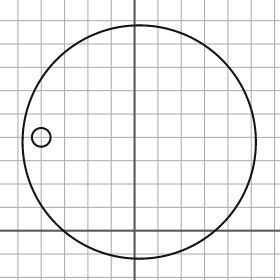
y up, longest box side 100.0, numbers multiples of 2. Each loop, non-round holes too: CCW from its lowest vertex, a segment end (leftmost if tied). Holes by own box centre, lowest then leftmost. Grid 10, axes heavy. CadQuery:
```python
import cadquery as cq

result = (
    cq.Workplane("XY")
    .moveTo(2.0, 38.0)
    .circle(50.0)
    .moveTo(-40.0, 40.0)
    .circle(4.0)
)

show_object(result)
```